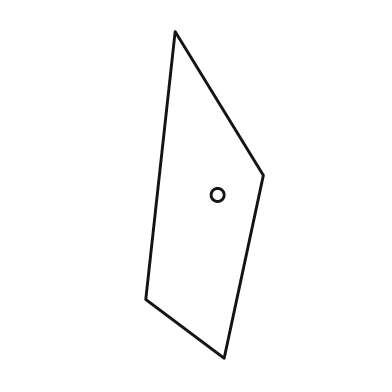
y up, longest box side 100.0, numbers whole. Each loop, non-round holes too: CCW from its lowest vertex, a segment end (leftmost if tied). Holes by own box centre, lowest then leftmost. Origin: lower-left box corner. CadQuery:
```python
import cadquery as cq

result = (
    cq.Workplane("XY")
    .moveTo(24.0, 0.0)
    .lineTo(36.0, 56.0)
    .lineTo(9.0, 100.0)
    .lineTo(0.0, 18.0)
    .close()
    .moveTo(22.0, 50.0)
    .circle(2.0)
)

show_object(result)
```